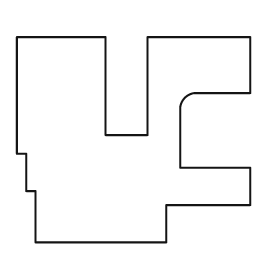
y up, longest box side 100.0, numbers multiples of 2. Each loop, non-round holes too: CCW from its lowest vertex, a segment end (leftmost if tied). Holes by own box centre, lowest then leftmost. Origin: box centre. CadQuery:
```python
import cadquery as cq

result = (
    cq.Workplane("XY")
    .moveTo(-42.0, -44.0)
    .lineTo(14.0, -44.0)
    .lineTo(14.0, -28.0)
    .lineTo(50.0, -28.0)
    .lineTo(50.0, -12.0)
    .lineTo(20.0, -12.0)
    .lineTo(20.0, 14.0)
    .threePointArc((22.0, 18.0), (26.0, 20.0))
    .lineTo(50.0, 20.0)
    .lineTo(50.0, 44.0)
    .lineTo(6.0, 44.0)
    .lineTo(6.0, 2.0)
    .lineTo(-12.0, 2.0)
    .lineTo(-12.0, 44.0)
    .lineTo(-50.0, 44.0)
    .lineTo(-50.0, -6.0)
    .lineTo(-46.0, -6.0)
    .lineTo(-46.0, -22.0)
    .lineTo(-42.0, -22.0)
    .close()
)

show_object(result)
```